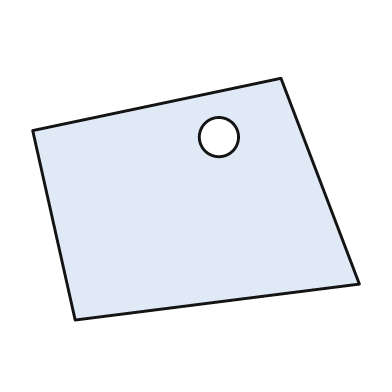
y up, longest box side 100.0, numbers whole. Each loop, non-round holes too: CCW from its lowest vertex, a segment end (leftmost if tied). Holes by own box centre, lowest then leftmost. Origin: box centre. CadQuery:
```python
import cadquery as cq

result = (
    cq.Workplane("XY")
    .moveTo(-37.0, -37.0)
    .lineTo(50.0, -26.0)
    .lineTo(26.0, 37.0)
    .lineTo(-50.0, 21.0)
    .close()
    .moveTo(7.0, 19.0)
    .circle(6.0)
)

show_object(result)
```